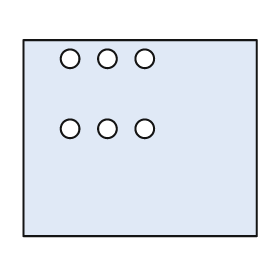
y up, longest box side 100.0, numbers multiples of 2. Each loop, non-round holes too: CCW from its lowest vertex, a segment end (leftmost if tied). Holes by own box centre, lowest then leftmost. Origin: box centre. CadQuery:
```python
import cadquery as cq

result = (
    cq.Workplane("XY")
    .moveTo(-50.0, -42.0)
    .lineTo(50.0, -42.0)
    .lineTo(50.0, 42.0)
    .lineTo(-50.0, 42.0)
    .close()
    .moveTo(-30.0, 4.0)
    .circle(4.0)
    .moveTo(-14.0, 4.0)
    .circle(4.0)
    .moveTo(2.0, 4.0)
    .circle(4.0)
    .moveTo(-30.0, 34.0)
    .circle(4.0)
    .moveTo(-14.0, 34.0)
    .circle(4.0)
    .moveTo(2.0, 34.0)
    .circle(4.0)
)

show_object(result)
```